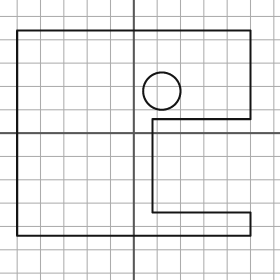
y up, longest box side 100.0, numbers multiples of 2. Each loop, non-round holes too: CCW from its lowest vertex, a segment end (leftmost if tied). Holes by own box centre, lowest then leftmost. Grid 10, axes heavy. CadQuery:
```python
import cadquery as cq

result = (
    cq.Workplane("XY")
    .moveTo(-50.0, -44.0)
    .lineTo(50.0, -44.0)
    .lineTo(50.0, -34.0)
    .lineTo(8.0, -34.0)
    .lineTo(8.0, 6.0)
    .lineTo(50.0, 6.0)
    .lineTo(50.0, 44.0)
    .lineTo(-50.0, 44.0)
    .close()
    .moveTo(12.0, 18.0)
    .circle(8.0)
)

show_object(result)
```